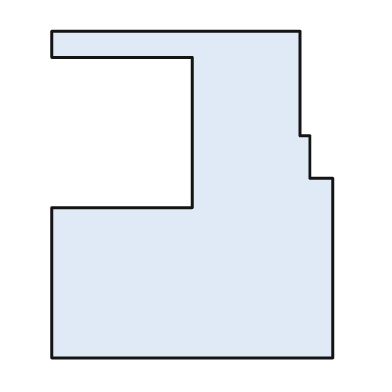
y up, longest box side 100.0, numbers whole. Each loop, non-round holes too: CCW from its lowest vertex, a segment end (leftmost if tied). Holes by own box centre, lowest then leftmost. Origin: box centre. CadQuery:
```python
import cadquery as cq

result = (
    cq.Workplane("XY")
    .moveTo(-43.0, -50.0)
    .lineTo(43.0, -50.0)
    .lineTo(43.0, 5.0)
    .lineTo(36.0, 5.0)
    .lineTo(36.0, 18.0)
    .lineTo(33.0, 18.0)
    .lineTo(33.0, 50.0)
    .lineTo(-43.0, 50.0)
    .lineTo(-43.0, 42.0)
    .lineTo(0.0, 42.0)
    .lineTo(0.0, -4.0)
    .lineTo(-43.0, -4.0)
    .close()
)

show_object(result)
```